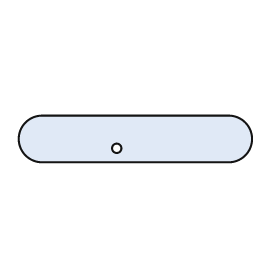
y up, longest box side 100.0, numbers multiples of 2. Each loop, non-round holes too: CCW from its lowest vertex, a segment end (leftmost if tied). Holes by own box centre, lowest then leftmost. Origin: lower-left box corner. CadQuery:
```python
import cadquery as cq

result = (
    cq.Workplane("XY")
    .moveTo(10.0, 0.0)
    .lineTo(90.0, 0.0)
    .threePointArc((100.0, 10.0), (90.0, 20.0))
    .lineTo(10.0, 20.0)
    .threePointArc((0.0, 10.0), (10.0, 0.0))
    .close()
    .moveTo(42.0, 6.0)
    .circle(2.0)
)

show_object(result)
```